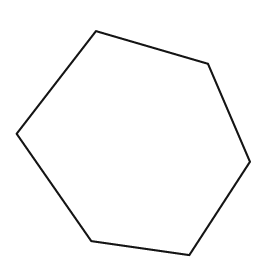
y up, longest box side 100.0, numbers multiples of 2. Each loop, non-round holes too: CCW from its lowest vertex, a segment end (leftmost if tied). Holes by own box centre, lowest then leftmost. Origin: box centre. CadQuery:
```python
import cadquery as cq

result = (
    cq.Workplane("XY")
    .moveTo(24.0, -48.0)
    .lineTo(50.0, -8.0)
    .lineTo(32.0, 34.0)
    .lineTo(-16.0, 48.0)
    .lineTo(-50.0, 4.0)
    .lineTo(-18.0, -42.0)
    .close()
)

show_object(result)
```